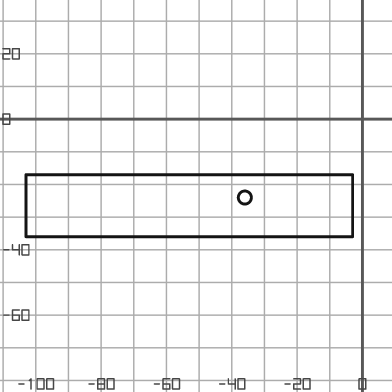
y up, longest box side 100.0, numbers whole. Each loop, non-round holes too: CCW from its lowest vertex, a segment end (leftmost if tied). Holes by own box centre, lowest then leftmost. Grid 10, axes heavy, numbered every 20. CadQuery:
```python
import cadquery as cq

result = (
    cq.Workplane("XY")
    .moveTo(-103.0, -36.0)
    .lineTo(-3.0, -36.0)
    .lineTo(-3.0, -17.0)
    .lineTo(-103.0, -17.0)
    .close()
    .moveTo(-36.0, -24.0)
    .circle(2.0)
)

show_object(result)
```